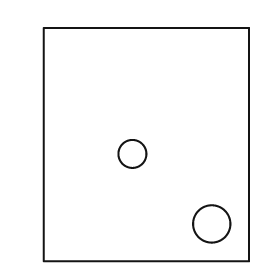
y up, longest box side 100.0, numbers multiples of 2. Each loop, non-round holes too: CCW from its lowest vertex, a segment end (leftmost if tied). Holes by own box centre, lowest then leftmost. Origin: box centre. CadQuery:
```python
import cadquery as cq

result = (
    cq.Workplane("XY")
    .moveTo(-44.0, -50.0)
    .lineTo(44.0, -50.0)
    .lineTo(44.0, 50.0)
    .lineTo(-44.0, 50.0)
    .close()
    .moveTo(28.0, -34.0)
    .circle(8.0)
    .moveTo(-6.0, -4.0)
    .circle(6.0)
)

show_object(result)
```